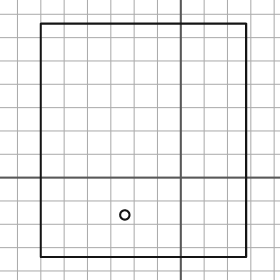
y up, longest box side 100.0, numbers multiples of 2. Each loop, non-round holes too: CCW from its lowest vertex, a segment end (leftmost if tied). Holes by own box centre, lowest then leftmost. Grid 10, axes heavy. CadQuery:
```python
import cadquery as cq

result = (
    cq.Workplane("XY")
    .moveTo(-60.0, -34.0)
    .lineTo(28.0, -34.0)
    .lineTo(28.0, 66.0)
    .lineTo(-60.0, 66.0)
    .close()
    .moveTo(-24.0, -16.0)
    .circle(2.0)
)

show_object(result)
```